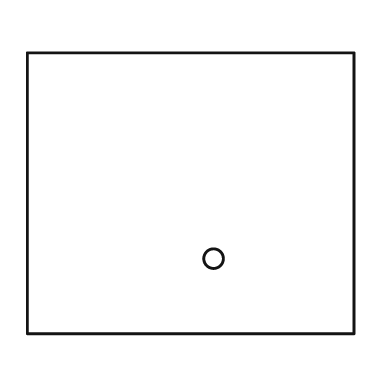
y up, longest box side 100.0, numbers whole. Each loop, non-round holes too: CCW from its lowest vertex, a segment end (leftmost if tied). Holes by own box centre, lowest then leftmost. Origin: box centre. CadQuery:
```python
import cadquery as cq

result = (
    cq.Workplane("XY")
    .moveTo(-50.0, -43.0)
    .lineTo(50.0, -43.0)
    .lineTo(50.0, 43.0)
    .lineTo(-50.0, 43.0)
    .close()
    .moveTo(7.0, -20.0)
    .circle(3.0)
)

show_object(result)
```